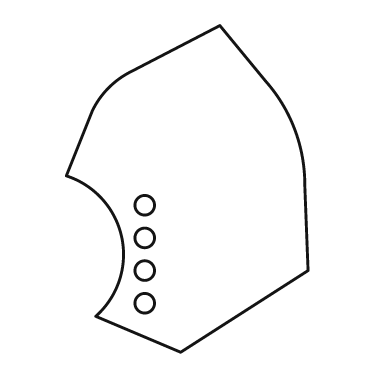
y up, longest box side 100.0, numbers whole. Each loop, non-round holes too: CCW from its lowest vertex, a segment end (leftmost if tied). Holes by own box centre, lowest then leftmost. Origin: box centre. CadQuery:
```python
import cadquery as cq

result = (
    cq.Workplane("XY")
    .moveTo(-2.0, -50.0)
    .lineTo(37.0, -25.0)
    .lineTo(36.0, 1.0)
    .threePointArc((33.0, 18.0), (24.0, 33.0))
    .lineTo(10.0, 50.0)
    .lineTo(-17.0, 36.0)
    .threePointArc((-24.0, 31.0), (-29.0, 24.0))
    .lineTo(-37.0, 4.0)
    .threePointArc((-20.0, -15.0), (-28.0, -39.0))
    .close()
    .moveTo(-13.0, -35.0)
    .circle(3.0)
    .moveTo(-13.0, -25.0)
    .circle(3.0)
    .moveTo(-13.0, -15.0)
    .circle(3.0)
    .moveTo(-13.0, -5.0)
    .circle(3.0)
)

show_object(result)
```